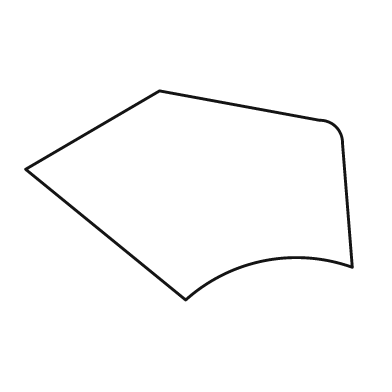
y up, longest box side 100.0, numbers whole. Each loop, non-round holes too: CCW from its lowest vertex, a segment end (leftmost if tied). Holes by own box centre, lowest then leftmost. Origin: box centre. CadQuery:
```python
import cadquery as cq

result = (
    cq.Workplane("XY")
    .moveTo(-1.0, -32.0)
    .threePointArc((23.0, -20.0), (50.0, -22.0))
    .lineTo(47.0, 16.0)
    .threePointArc((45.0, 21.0), (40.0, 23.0))
    .lineTo(-9.0, 32.0)
    .lineTo(-50.0, 8.0)
    .close()
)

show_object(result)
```